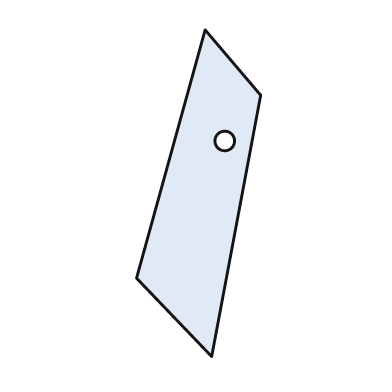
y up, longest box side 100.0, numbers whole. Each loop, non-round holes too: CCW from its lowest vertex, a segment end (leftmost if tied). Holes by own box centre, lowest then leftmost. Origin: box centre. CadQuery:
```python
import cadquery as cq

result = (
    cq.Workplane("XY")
    .moveTo(4.0, -50.0)
    .lineTo(19.0, 30.0)
    .lineTo(2.0, 50.0)
    .lineTo(-19.0, -26.0)
    .close()
    .moveTo(8.0, 16.0)
    .circle(3.0)
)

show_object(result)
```